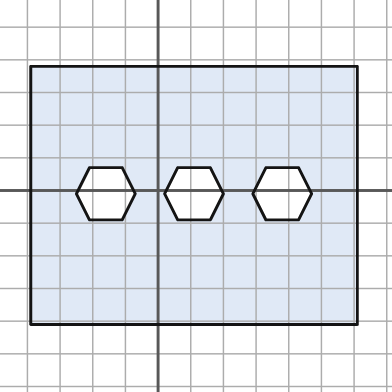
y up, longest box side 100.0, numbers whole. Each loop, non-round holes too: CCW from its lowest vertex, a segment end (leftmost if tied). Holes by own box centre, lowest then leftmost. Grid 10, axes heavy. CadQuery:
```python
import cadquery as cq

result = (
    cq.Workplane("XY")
    .moveTo(-39.0, -41.0)
    .lineTo(61.0, -41.0)
    .lineTo(61.0, 38.0)
    .lineTo(-39.0, 38.0)
    .close()
    .moveTo(-21.0, -9.0)
    .lineTo(-11.0, -9.0)
    .lineTo(-7.0, -1.0)
    .lineTo(-11.0, 7.0)
    .lineTo(-21.0, 7.0)
    .lineTo(-25.0, -1.0)
    .close()
    .moveTo(6.0, -9.0)
    .lineTo(16.0, -9.0)
    .lineTo(20.0, -1.0)
    .lineTo(16.0, 7.0)
    .lineTo(6.0, 7.0)
    .lineTo(2.0, -1.0)
    .close()
    .moveTo(33.0, -9.0)
    .lineTo(43.0, -9.0)
    .lineTo(47.0, -1.0)
    .lineTo(43.0, 7.0)
    .lineTo(33.0, 7.0)
    .lineTo(29.0, -1.0)
    .close()
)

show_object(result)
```